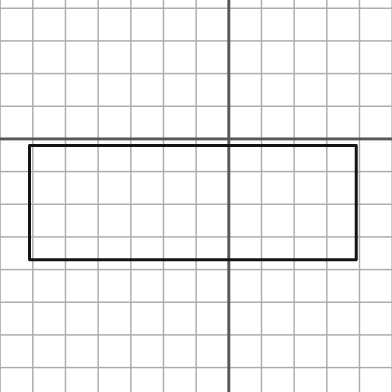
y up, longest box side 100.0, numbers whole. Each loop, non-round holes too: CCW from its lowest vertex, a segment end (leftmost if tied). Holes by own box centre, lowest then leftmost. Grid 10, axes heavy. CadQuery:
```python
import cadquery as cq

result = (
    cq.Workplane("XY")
    .moveTo(-61.0, -37.0)
    .lineTo(39.0, -37.0)
    .lineTo(39.0, -2.0)
    .lineTo(-61.0, -2.0)
    .close()
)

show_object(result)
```